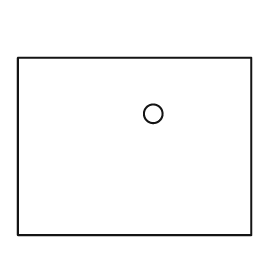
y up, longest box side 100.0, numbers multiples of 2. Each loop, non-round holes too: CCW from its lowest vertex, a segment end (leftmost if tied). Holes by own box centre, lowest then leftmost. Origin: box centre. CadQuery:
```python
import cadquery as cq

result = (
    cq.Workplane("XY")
    .moveTo(-50.0, -38.0)
    .lineTo(50.0, -38.0)
    .lineTo(50.0, 38.0)
    .lineTo(-50.0, 38.0)
    .close()
    .moveTo(8.0, 14.0)
    .circle(4.0)
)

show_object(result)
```